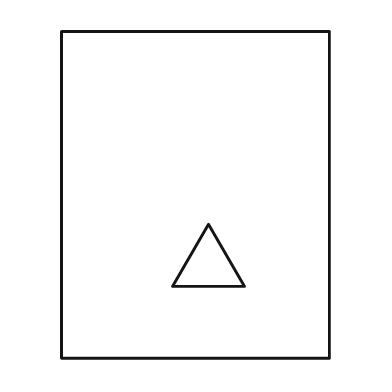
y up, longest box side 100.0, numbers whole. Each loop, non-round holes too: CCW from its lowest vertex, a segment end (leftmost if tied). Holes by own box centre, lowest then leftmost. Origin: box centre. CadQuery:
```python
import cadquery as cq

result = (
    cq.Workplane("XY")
    .moveTo(-41.0, -50.0)
    .lineTo(41.0, -50.0)
    .lineTo(41.0, 50.0)
    .lineTo(-41.0, 50.0)
    .close()
    .moveTo(-7.0, -28.0)
    .lineTo(15.0, -28.0)
    .lineTo(4.0, -9.0)
    .close()
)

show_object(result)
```